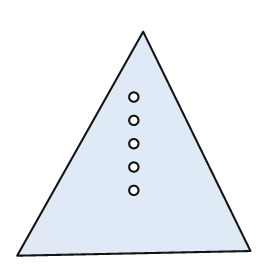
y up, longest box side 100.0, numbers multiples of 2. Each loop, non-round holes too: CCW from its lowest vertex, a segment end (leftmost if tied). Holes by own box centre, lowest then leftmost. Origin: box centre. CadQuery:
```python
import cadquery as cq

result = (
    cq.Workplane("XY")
    .moveTo(-50.0, -48.0)
    .lineTo(50.0, -46.0)
    .lineTo(4.0, 48.0)
    .close()
    .moveTo(0.0, -20.0)
    .circle(2.0)
    .moveTo(0.0, -10.0)
    .circle(2.0)
    .moveTo(0.0, 0.0)
    .circle(2.0)
    .moveTo(0.0, 10.0)
    .circle(2.0)
    .moveTo(0.0, 20.0)
    .circle(2.0)
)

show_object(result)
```